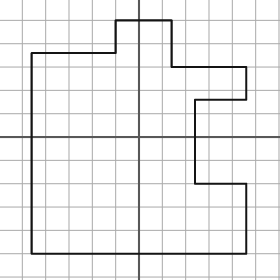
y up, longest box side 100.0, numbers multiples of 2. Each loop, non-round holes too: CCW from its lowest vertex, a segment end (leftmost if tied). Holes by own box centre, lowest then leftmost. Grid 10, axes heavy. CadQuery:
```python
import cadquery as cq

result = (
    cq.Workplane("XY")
    .moveTo(-46.0, -50.0)
    .lineTo(46.0, -50.0)
    .lineTo(46.0, -20.0)
    .lineTo(24.0, -20.0)
    .lineTo(24.0, 16.0)
    .lineTo(46.0, 16.0)
    .lineTo(46.0, 30.0)
    .lineTo(14.0, 30.0)
    .lineTo(14.0, 50.0)
    .lineTo(-10.0, 50.0)
    .lineTo(-10.0, 36.0)
    .lineTo(-46.0, 36.0)
    .close()
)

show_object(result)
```